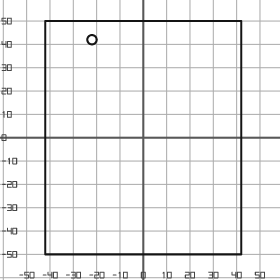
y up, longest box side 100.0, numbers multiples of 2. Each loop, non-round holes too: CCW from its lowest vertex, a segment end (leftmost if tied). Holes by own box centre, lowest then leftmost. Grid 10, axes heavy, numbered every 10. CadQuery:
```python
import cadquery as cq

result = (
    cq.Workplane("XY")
    .moveTo(-42.0, -50.0)
    .lineTo(42.0, -50.0)
    .lineTo(42.0, 50.0)
    .lineTo(-42.0, 50.0)
    .close()
    .moveTo(-22.0, 42.0)
    .circle(2.0)
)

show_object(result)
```